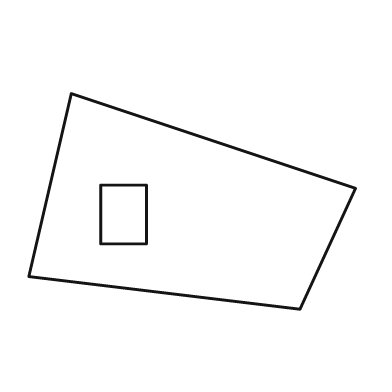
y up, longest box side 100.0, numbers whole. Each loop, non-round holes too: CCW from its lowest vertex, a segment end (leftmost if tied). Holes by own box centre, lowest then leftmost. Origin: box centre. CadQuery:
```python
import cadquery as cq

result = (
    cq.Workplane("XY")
    .moveTo(33.0, -33.0)
    .lineTo(50.0, 4.0)
    .lineTo(-37.0, 33.0)
    .lineTo(-50.0, -23.0)
    .close()
    .moveTo(-28.0, -13.0)
    .lineTo(-14.0, -13.0)
    .lineTo(-14.0, 5.0)
    .lineTo(-28.0, 5.0)
    .close()
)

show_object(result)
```